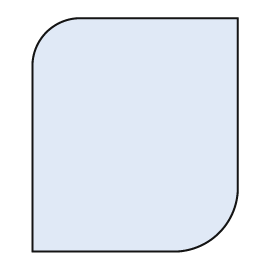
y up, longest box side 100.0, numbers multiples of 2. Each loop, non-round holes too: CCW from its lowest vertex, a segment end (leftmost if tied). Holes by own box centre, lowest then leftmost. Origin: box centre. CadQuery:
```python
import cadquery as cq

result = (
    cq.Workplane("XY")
    .moveTo(-44.0, -50.0)
    .lineTo(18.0, -50.0)
    .threePointArc((36.0, -42.0), (44.0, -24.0))
    .lineTo(44.0, 50.0)
    .lineTo(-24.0, 50.0)
    .threePointArc((-38.0, 44.0), (-44.0, 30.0))
    .close()
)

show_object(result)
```